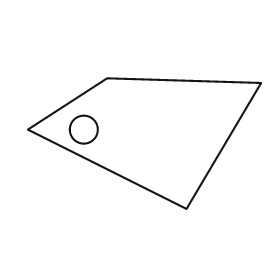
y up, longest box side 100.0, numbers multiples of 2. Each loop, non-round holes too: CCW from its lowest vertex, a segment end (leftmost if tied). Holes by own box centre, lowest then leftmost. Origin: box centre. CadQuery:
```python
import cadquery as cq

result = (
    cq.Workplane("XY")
    .moveTo(18.0, -28.0)
    .lineTo(50.0, 26.0)
    .lineTo(-16.0, 28.0)
    .lineTo(-50.0, 6.0)
    .close()
    .moveTo(-26.0, 6.0)
    .circle(6.0)
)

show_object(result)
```